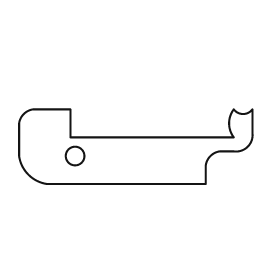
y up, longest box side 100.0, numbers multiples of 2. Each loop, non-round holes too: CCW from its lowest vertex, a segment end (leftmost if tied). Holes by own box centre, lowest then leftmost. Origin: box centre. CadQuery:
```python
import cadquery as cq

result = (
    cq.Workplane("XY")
    .moveTo(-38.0, -16.0)
    .lineTo(30.0, -16.0)
    .lineTo(30.0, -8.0)
    .threePointArc((32.0, -4.0), (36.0, -2.0))
    .lineTo(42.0, -2.0)
    .threePointArc((48.0, 0.0), (50.0, 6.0))
    .lineTo(50.0, 16.0)
    .threePointArc((46.0, 14.0), (42.0, 16.0))
    .threePointArc((40.0, 10.0), (42.0, 4.0))
    .lineTo(-28.0, 4.0)
    .lineTo(-28.0, 16.0)
    .lineTo(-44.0, 16.0)
    .threePointArc((-48.0, 14.0), (-50.0, 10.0))
    .lineTo(-50.0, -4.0)
    .threePointArc((-46.0, -12.0), (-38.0, -16.0))
    .close()
    .moveTo(-26.0, -4.0)
    .circle(4.0)
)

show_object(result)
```